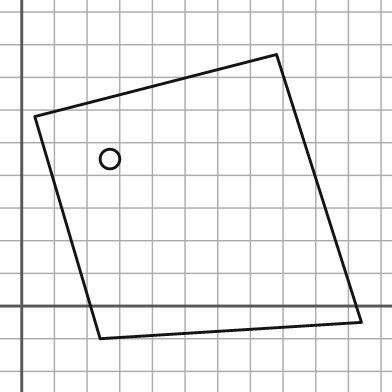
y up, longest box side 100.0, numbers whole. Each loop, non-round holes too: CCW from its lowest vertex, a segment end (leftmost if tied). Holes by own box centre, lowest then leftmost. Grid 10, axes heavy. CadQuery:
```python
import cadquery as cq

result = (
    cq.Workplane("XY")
    .moveTo(24.0, -10.0)
    .lineTo(104.0, -5.0)
    .lineTo(78.0, 77.0)
    .lineTo(4.0, 58.0)
    .close()
    .moveTo(27.0, 45.0)
    .circle(3.0)
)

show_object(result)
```